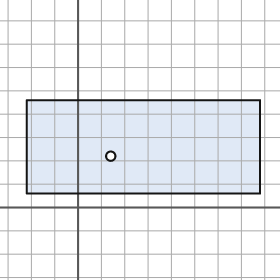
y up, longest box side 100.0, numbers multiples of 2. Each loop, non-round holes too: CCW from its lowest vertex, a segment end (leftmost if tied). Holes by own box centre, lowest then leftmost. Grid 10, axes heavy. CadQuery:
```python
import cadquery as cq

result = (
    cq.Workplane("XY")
    .moveTo(-22.0, 6.0)
    .lineTo(78.0, 6.0)
    .lineTo(78.0, 46.0)
    .lineTo(-22.0, 46.0)
    .close()
    .moveTo(14.0, 22.0)
    .circle(2.0)
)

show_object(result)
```